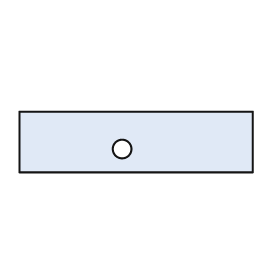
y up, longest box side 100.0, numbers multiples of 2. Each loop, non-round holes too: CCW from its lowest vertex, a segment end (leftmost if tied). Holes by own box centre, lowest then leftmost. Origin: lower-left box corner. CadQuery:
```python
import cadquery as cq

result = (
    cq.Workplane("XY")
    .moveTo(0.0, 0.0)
    .lineTo(100.0, 0.0)
    .lineTo(100.0, 26.0)
    .lineTo(0.0, 26.0)
    .close()
    .moveTo(44.0, 10.0)
    .circle(4.0)
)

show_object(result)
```